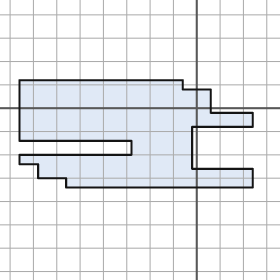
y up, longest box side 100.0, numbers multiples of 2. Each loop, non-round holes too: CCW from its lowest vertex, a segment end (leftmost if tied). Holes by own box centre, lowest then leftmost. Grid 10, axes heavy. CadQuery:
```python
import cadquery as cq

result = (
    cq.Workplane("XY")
    .moveTo(-56.0, -34.0)
    .lineTo(24.0, -34.0)
    .lineTo(24.0, -26.0)
    .lineTo(-2.0, -26.0)
    .lineTo(-2.0, -8.0)
    .lineTo(24.0, -8.0)
    .lineTo(24.0, -2.0)
    .lineTo(6.0, -2.0)
    .lineTo(6.0, 8.0)
    .lineTo(-6.0, 8.0)
    .lineTo(-6.0, 12.0)
    .lineTo(-76.0, 12.0)
    .lineTo(-76.0, -14.0)
    .lineTo(-28.0, -14.0)
    .lineTo(-28.0, -20.0)
    .lineTo(-76.0, -20.0)
    .lineTo(-76.0, -24.0)
    .lineTo(-68.0, -24.0)
    .lineTo(-68.0, -30.0)
    .lineTo(-56.0, -30.0)
    .close()
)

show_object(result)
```